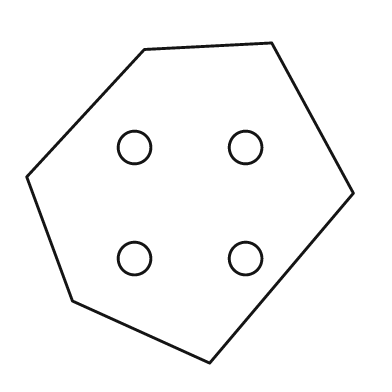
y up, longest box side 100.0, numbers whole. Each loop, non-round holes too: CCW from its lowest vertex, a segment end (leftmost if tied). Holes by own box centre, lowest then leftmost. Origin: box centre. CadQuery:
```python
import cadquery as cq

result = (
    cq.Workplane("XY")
    .moveTo(6.0, -49.0)
    .lineTo(50.0, 3.0)
    .lineTo(25.0, 49.0)
    .lineTo(-14.0, 47.0)
    .lineTo(-50.0, 8.0)
    .lineTo(-36.0, -30.0)
    .close()
    .moveTo(-17.0, -17.0)
    .circle(5.0)
    .moveTo(17.0, -17.0)
    .circle(5.0)
    .moveTo(-17.0, 17.0)
    .circle(5.0)
    .moveTo(17.0, 17.0)
    .circle(5.0)
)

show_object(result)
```